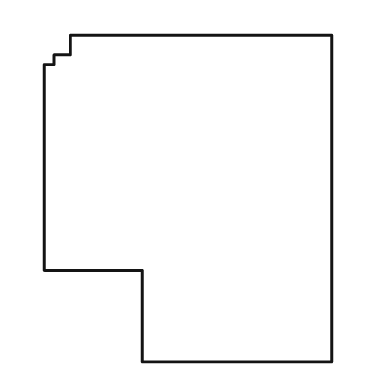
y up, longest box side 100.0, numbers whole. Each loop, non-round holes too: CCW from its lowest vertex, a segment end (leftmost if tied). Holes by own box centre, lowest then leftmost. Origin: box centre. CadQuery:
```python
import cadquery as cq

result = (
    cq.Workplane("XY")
    .moveTo(-14.0, -50.0)
    .lineTo(44.0, -50.0)
    .lineTo(44.0, 50.0)
    .lineTo(-36.0, 50.0)
    .lineTo(-36.0, 44.0)
    .lineTo(-41.0, 44.0)
    .lineTo(-41.0, 41.0)
    .lineTo(-44.0, 41.0)
    .lineTo(-44.0, -22.0)
    .lineTo(-14.0, -22.0)
    .close()
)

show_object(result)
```